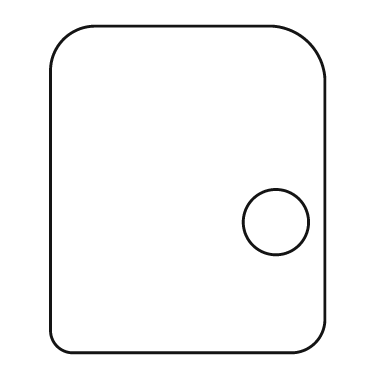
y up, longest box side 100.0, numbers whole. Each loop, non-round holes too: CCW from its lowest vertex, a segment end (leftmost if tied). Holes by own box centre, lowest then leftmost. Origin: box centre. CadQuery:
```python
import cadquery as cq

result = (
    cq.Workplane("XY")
    .moveTo(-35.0, -50.0)
    .lineTo(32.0, -50.0)
    .threePointArc((39.0, -47.0), (42.0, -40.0))
    .lineTo(42.0, 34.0)
    .threePointArc((37.0, 45.0), (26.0, 50.0))
    .lineTo(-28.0, 50.0)
    .threePointArc((-38.0, 46.0), (-42.0, 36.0))
    .lineTo(-42.0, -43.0)
    .threePointArc((-40.0, -48.0), (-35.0, -50.0))
    .close()
    .moveTo(27.0, -10.0)
    .circle(10.0)
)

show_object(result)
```